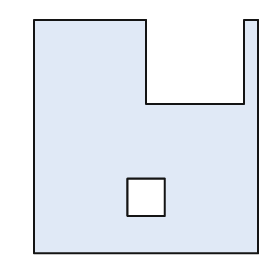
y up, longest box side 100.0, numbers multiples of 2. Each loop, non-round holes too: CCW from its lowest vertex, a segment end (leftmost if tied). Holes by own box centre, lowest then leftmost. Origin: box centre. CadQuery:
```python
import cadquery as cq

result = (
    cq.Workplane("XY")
    .moveTo(-48.0, -50.0)
    .lineTo(48.0, -50.0)
    .lineTo(48.0, 50.0)
    .lineTo(42.0, 50.0)
    .lineTo(42.0, 14.0)
    .lineTo(0.0, 14.0)
    .lineTo(0.0, 50.0)
    .lineTo(-48.0, 50.0)
    .close()
    .moveTo(-8.0, -34.0)
    .lineTo(8.0, -34.0)
    .lineTo(8.0, -18.0)
    .lineTo(-8.0, -18.0)
    .close()
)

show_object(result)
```